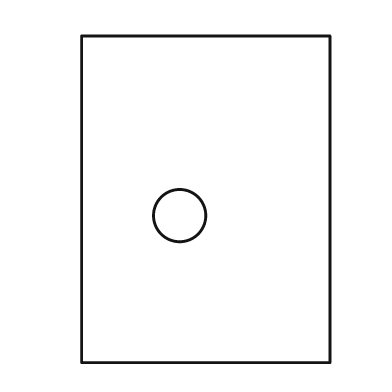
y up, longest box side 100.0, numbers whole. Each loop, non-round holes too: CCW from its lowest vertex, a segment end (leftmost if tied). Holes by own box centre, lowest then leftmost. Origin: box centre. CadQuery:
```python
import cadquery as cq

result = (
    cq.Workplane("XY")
    .moveTo(-38.0, -50.0)
    .lineTo(38.0, -50.0)
    .lineTo(38.0, 50.0)
    .lineTo(-38.0, 50.0)
    .close()
    .moveTo(-8.0, -5.0)
    .circle(8.0)
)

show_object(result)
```